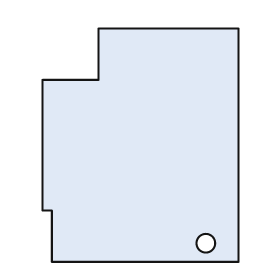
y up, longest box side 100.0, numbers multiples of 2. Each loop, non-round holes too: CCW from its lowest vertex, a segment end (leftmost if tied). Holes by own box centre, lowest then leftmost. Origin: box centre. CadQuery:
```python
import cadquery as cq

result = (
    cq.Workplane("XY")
    .moveTo(-38.0, -50.0)
    .lineTo(42.0, -50.0)
    .lineTo(42.0, 50.0)
    .lineTo(-18.0, 50.0)
    .lineTo(-18.0, 28.0)
    .lineTo(-42.0, 28.0)
    .lineTo(-42.0, -28.0)
    .lineTo(-38.0, -28.0)
    .close()
    .moveTo(28.0, -42.0)
    .circle(4.0)
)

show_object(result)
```